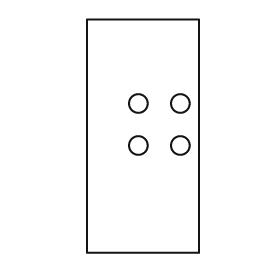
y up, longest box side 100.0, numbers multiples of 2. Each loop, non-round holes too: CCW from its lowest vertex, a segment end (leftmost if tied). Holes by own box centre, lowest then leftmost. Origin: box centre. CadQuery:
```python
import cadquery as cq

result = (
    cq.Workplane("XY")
    .moveTo(-24.0, -50.0)
    .lineTo(24.0, -50.0)
    .lineTo(24.0, 50.0)
    .lineTo(-24.0, 50.0)
    .close()
    .moveTo(-2.0, -4.0)
    .circle(4.0)
    .moveTo(16.0, -4.0)
    .circle(4.0)
    .moveTo(-2.0, 14.0)
    .circle(4.0)
    .moveTo(16.0, 14.0)
    .circle(4.0)
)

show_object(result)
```